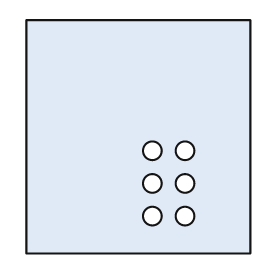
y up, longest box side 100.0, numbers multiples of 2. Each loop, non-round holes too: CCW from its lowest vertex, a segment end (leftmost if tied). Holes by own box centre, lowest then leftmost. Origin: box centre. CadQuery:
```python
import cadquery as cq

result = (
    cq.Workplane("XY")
    .moveTo(-48.0, -50.0)
    .lineTo(48.0, -50.0)
    .lineTo(48.0, 50.0)
    .lineTo(-48.0, 50.0)
    .close()
    .moveTo(6.0, -34.0)
    .circle(4.0)
    .moveTo(20.0, -34.0)
    .circle(4.0)
    .moveTo(6.0, -20.0)
    .circle(4.0)
    .moveTo(20.0, -20.0)
    .circle(4.0)
    .moveTo(6.0, -6.0)
    .circle(4.0)
    .moveTo(20.0, -6.0)
    .circle(4.0)
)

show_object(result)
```